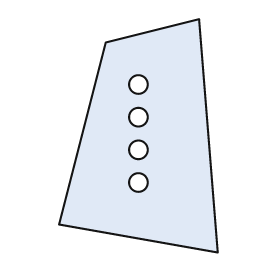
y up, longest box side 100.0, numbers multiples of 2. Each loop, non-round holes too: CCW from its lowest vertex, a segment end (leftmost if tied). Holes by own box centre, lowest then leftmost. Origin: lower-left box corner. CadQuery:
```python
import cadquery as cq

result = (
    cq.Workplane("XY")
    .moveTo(68.0, 0.0)
    .lineTo(60.0, 100.0)
    .lineTo(20.0, 90.0)
    .lineTo(0.0, 12.0)
    .close()
    .moveTo(34.0, 30.0)
    .circle(4.0)
    .moveTo(34.0, 44.0)
    .circle(4.0)
    .moveTo(34.0, 58.0)
    .circle(4.0)
    .moveTo(34.0, 72.0)
    .circle(4.0)
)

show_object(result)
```